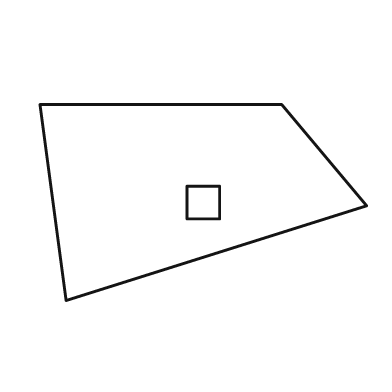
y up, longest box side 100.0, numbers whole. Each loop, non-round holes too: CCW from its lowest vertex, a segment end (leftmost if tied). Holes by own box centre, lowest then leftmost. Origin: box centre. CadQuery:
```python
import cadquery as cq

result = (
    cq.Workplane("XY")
    .moveTo(-42.0, -30.0)
    .lineTo(50.0, -1.0)
    .lineTo(24.0, 30.0)
    .lineTo(-50.0, 30.0)
    .close()
    .moveTo(-5.0, -5.0)
    .lineTo(5.0, -5.0)
    .lineTo(5.0, 5.0)
    .lineTo(-5.0, 5.0)
    .close()
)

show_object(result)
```